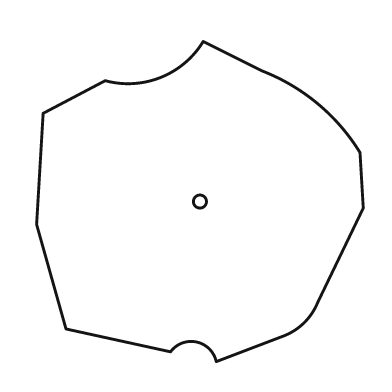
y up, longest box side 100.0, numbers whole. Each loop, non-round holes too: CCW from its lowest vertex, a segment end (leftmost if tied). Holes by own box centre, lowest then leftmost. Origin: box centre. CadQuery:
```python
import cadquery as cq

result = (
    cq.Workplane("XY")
    .moveTo(5.0, -49.0)
    .lineTo(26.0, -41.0)
    .threePointArc((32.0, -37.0), (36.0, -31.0))
    .lineTo(50.0, -2.0)
    .lineTo(49.0, 15.0)
    .threePointArc((36.0, 30.0), (19.0, 40.0))
    .lineTo(1.0, 49.0)
    .threePointArc((-12.0, 38.0), (-29.0, 37.0))
    .lineTo(-48.0, 27.0)
    .lineTo(-50.0, -7.0)
    .lineTo(-41.0, -39.0)
    .lineTo(-9.0, -46.0)
    .threePointArc((-1.0, -43.0), (5.0, -49.0))
    .close()
    .moveTo(0.0, 0.0)
    .circle(2.0)
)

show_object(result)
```